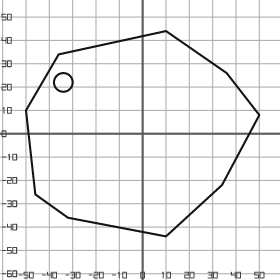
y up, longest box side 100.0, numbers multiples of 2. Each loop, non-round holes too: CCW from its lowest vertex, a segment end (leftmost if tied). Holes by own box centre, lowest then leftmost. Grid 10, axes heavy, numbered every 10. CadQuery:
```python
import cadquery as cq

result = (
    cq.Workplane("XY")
    .moveTo(10.0, -44.0)
    .lineTo(34.0, -22.0)
    .lineTo(50.0, 8.0)
    .lineTo(36.0, 26.0)
    .lineTo(10.0, 44.0)
    .lineTo(-36.0, 34.0)
    .lineTo(-50.0, 10.0)
    .lineTo(-46.0, -26.0)
    .lineTo(-32.0, -36.0)
    .close()
    .moveTo(-34.0, 22.0)
    .circle(4.0)
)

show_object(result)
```